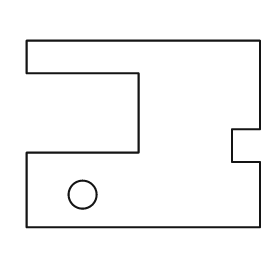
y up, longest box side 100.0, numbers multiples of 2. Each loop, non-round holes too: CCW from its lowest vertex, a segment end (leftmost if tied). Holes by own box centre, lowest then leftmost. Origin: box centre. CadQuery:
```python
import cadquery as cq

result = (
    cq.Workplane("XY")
    .moveTo(-50.0, -40.0)
    .lineTo(50.0, -40.0)
    .lineTo(50.0, -12.0)
    .lineTo(38.0, -12.0)
    .lineTo(38.0, 2.0)
    .lineTo(50.0, 2.0)
    .lineTo(50.0, 40.0)
    .lineTo(-50.0, 40.0)
    .lineTo(-50.0, 26.0)
    .lineTo(-2.0, 26.0)
    .lineTo(-2.0, -8.0)
    .lineTo(-50.0, -8.0)
    .close()
    .moveTo(-26.0, -26.0)
    .circle(6.0)
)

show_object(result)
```